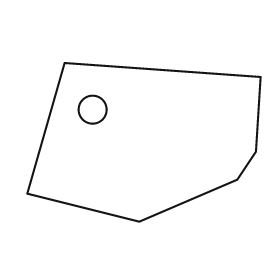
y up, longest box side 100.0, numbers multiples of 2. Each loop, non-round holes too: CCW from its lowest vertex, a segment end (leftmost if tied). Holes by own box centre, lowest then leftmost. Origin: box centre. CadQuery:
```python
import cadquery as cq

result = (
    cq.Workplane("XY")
    .moveTo(-2.0, -34.0)
    .lineTo(40.0, -16.0)
    .lineTo(48.0, -4.0)
    .lineTo(50.0, 28.0)
    .lineTo(-34.0, 34.0)
    .lineTo(-50.0, -22.0)
    .close()
    .moveTo(-22.0, 14.0)
    .circle(6.0)
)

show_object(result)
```